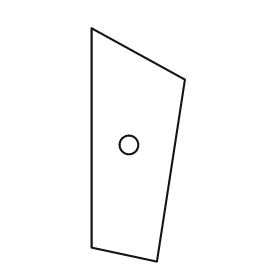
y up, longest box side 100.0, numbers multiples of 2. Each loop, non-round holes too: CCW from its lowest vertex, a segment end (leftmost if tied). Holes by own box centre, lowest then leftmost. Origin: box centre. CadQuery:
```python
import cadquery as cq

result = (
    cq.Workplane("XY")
    .moveTo(8.0, -50.0)
    .lineTo(20.0, 28.0)
    .lineTo(-20.0, 50.0)
    .lineTo(-20.0, -44.0)
    .close()
    .moveTo(-4.0, 0.0)
    .circle(4.0)
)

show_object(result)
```